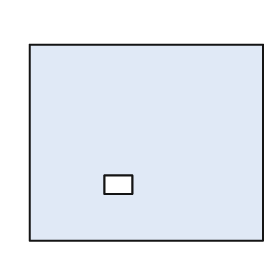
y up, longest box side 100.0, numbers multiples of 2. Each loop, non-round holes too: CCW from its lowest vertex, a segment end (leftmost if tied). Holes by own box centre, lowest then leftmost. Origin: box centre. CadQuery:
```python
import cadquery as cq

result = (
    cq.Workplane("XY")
    .moveTo(-50.0, -42.0)
    .lineTo(50.0, -42.0)
    .lineTo(50.0, 42.0)
    .lineTo(-50.0, 42.0)
    .close()
    .moveTo(-18.0, -22.0)
    .lineTo(-6.0, -22.0)
    .lineTo(-6.0, -14.0)
    .lineTo(-18.0, -14.0)
    .close()
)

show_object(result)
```